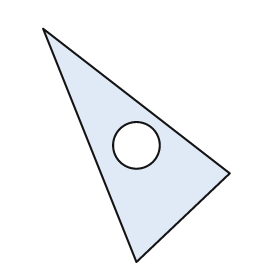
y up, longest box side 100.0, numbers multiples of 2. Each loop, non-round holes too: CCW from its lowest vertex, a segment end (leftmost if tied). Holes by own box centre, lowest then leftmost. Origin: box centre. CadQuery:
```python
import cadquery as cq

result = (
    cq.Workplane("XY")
    .moveTo(0.0, -50.0)
    .lineTo(40.0, -12.0)
    .lineTo(-40.0, 50.0)
    .close()
    .moveTo(0.0, 0.0)
    .circle(10.0)
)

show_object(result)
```